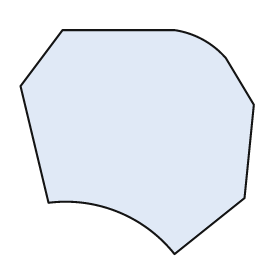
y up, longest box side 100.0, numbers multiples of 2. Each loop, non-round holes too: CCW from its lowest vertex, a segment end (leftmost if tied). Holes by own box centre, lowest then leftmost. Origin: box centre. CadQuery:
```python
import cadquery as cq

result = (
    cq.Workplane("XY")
    .moveTo(16.0, -48.0)
    .lineTo(46.0, -24.0)
    .lineTo(50.0, 16.0)
    .lineTo(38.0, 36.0)
    .threePointArc((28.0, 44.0), (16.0, 48.0))
    .lineTo(-32.0, 48.0)
    .lineTo(-50.0, 24.0)
    .lineTo(-38.0, -26.0)
    .threePointArc((-8.0, -30.0), (16.0, -48.0))
    .close()
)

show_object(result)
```